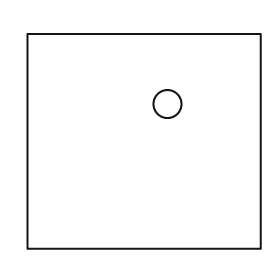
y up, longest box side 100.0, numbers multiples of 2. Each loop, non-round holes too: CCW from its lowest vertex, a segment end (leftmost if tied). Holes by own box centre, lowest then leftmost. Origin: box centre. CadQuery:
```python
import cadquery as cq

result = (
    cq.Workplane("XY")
    .moveTo(-50.0, -46.0)
    .lineTo(50.0, -46.0)
    .lineTo(50.0, 46.0)
    .lineTo(-50.0, 46.0)
    .close()
    .moveTo(10.0, 16.0)
    .circle(6.0)
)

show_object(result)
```